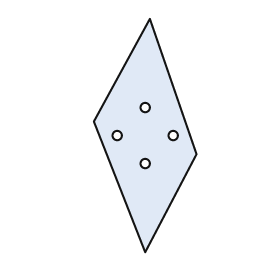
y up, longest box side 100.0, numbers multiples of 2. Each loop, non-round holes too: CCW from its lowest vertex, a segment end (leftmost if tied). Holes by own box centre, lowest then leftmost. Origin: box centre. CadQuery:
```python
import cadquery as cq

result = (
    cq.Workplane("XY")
    .moveTo(0.0, -50.0)
    .lineTo(22.0, -8.0)
    .lineTo(2.0, 50.0)
    .lineTo(-22.0, 6.0)
    .close()
    .moveTo(0.0, -12.0)
    .circle(2.0)
    .moveTo(-12.0, 0.0)
    .circle(2.0)
    .moveTo(12.0, 0.0)
    .circle(2.0)
    .moveTo(0.0, 12.0)
    .circle(2.0)
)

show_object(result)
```